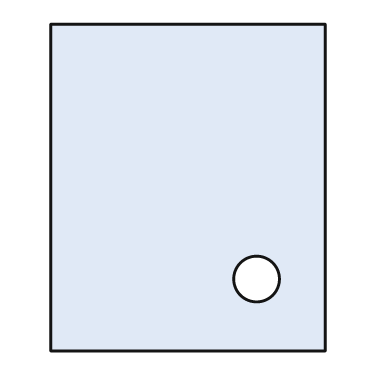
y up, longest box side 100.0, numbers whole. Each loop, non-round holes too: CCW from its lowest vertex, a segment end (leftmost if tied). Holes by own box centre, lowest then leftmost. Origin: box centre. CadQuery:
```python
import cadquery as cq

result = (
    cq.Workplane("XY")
    .moveTo(-42.0, -50.0)
    .lineTo(42.0, -50.0)
    .lineTo(42.0, 50.0)
    .lineTo(-42.0, 50.0)
    .close()
    .moveTo(21.0, -28.0)
    .circle(7.0)
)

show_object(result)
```